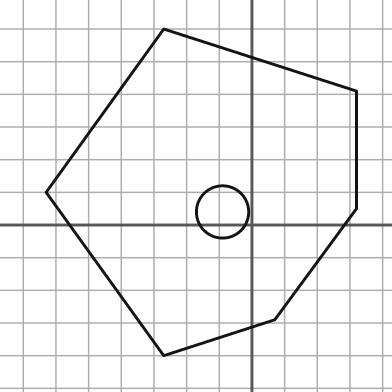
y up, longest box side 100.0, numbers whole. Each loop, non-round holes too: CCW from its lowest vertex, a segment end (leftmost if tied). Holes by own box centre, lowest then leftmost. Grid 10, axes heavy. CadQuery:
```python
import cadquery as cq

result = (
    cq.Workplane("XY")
    .moveTo(-27.0, -40.0)
    .lineTo(7.0, -29.0)
    .lineTo(32.0, 5.0)
    .lineTo(32.0, 41.0)
    .lineTo(-27.0, 60.0)
    .lineTo(-63.0, 10.0)
    .close()
    .moveTo(-9.0, 4.0)
    .circle(8.0)
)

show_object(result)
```